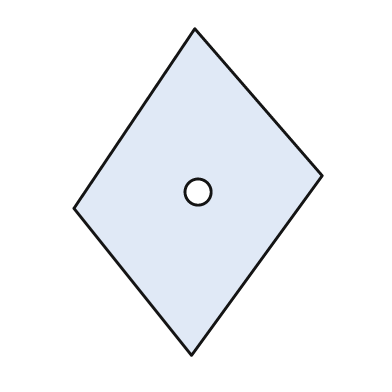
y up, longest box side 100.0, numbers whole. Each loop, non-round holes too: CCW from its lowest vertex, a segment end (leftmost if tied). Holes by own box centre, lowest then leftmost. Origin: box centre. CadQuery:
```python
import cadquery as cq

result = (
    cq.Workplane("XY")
    .moveTo(-2.0, -50.0)
    .lineTo(38.0, 5.0)
    .lineTo(-1.0, 50.0)
    .lineTo(-38.0, -5.0)
    .close()
    .moveTo(0.0, 0.0)
    .circle(4.0)
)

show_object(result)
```